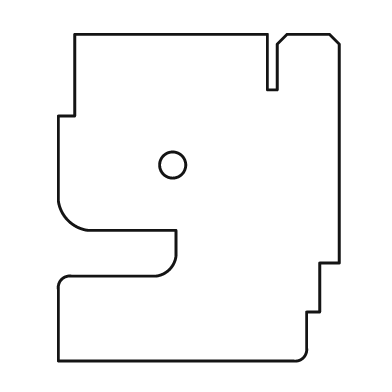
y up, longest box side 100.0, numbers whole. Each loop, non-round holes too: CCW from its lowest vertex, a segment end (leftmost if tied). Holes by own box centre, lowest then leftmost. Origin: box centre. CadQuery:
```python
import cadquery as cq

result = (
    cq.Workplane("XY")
    .moveTo(-43.0, -50.0)
    .lineTo(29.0, -50.0)
    .threePointArc((32.0, -49.0), (33.0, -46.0))
    .lineTo(33.0, -35.0)
    .lineTo(37.0, -35.0)
    .lineTo(37.0, -20.0)
    .lineTo(43.0, -20.0)
    .lineTo(43.0, 47.0)
    .lineTo(40.0, 50.0)
    .lineTo(27.0, 50.0)
    .lineTo(24.0, 47.0)
    .lineTo(24.0, 33.0)
    .lineTo(21.0, 33.0)
    .lineTo(21.0, 50.0)
    .lineTo(-38.0, 50.0)
    .lineTo(-38.0, 25.0)
    .lineTo(-43.0, 25.0)
    .lineTo(-43.0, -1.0)
    .threePointArc((-40.0, -7.0), (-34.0, -10.0))
    .lineTo(-7.0, -10.0)
    .lineTo(-7.0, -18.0)
    .threePointArc((-9.0, -22.0), (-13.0, -24.0))
    .lineTo(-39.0, -24.0)
    .threePointArc((-42.0, -25.0), (-43.0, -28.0))
    .close()
    .moveTo(-8.0, 10.0)
    .circle(4.0)
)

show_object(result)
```